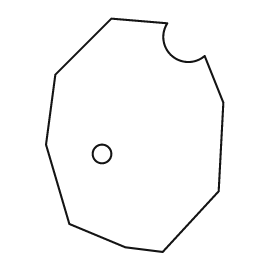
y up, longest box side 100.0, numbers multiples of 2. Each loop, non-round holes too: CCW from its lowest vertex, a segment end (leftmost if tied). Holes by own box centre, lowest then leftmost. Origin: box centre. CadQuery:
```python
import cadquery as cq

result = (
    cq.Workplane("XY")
    .moveTo(12.0, -50.0)
    .lineTo(36.0, -24.0)
    .lineTo(38.0, 14.0)
    .lineTo(30.0, 34.0)
    .threePointArc((16.0, 34.0), (14.0, 48.0))
    .lineTo(-10.0, 50.0)
    .lineTo(-34.0, 26.0)
    .lineTo(-38.0, -4.0)
    .lineTo(-28.0, -38.0)
    .lineTo(-4.0, -48.0)
    .close()
    .moveTo(-14.0, -8.0)
    .circle(4.0)
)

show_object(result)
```